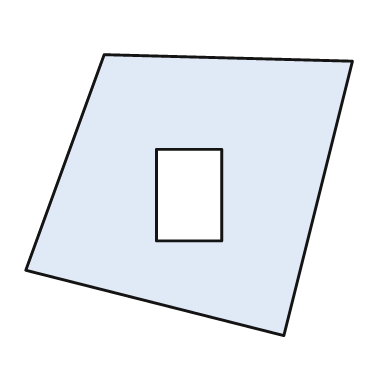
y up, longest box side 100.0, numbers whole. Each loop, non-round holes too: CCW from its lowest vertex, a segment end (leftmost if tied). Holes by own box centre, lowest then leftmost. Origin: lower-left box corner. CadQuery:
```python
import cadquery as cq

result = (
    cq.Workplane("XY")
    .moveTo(79.0, 0.0)
    .lineTo(100.0, 84.0)
    .lineTo(24.0, 86.0)
    .lineTo(0.0, 20.0)
    .close()
    .moveTo(40.0, 29.0)
    .lineTo(60.0, 29.0)
    .lineTo(60.0, 57.0)
    .lineTo(40.0, 57.0)
    .close()
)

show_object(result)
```